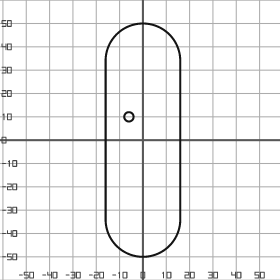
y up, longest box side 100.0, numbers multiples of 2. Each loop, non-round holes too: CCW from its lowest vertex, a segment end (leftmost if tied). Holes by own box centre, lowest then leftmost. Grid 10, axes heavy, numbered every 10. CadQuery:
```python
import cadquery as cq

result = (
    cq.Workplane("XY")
    .moveTo(-16.0, -34.0)
    .threePointArc((0.0, -50.0), (16.0, -34.0))
    .lineTo(16.0, 34.0)
    .threePointArc((0.0, 50.0), (-16.0, 34.0))
    .close()
    .moveTo(-6.0, 10.0)
    .circle(2.0)
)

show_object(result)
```